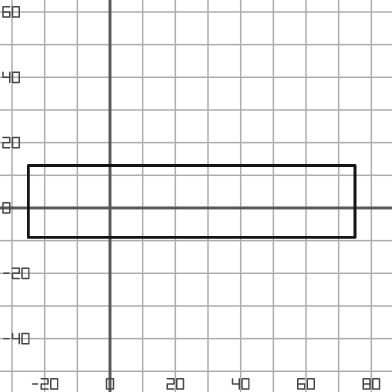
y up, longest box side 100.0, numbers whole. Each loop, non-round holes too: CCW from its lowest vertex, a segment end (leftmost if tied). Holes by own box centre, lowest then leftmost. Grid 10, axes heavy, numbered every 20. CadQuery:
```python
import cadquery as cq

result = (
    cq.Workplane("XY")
    .moveTo(-25.0, -9.0)
    .lineTo(75.0, -9.0)
    .lineTo(75.0, 13.0)
    .lineTo(-25.0, 13.0)
    .close()
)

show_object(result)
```